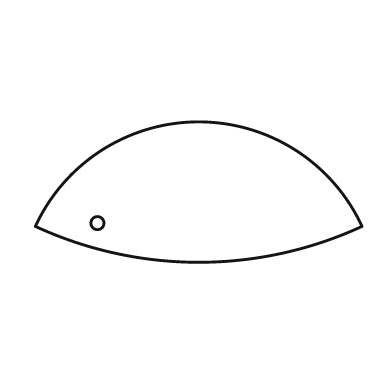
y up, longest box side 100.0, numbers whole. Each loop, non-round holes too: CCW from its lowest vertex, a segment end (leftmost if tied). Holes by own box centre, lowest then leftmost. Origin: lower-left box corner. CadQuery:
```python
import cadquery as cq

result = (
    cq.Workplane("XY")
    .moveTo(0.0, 11.0)
    .threePointArc((50.0, 0.0), (100.0, 11.0))
    .threePointArc((50.0, 43.0), (0.0, 11.0))
    .close()
    .moveTo(19.0, 12.0)
    .circle(2.0)
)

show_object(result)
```